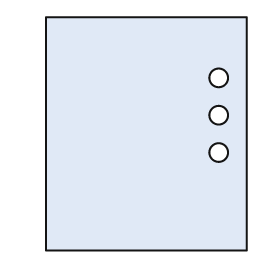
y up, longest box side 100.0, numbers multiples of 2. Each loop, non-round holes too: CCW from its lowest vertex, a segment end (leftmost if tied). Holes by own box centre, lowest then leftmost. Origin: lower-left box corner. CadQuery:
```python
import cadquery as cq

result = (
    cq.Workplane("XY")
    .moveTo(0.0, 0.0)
    .lineTo(86.0, 0.0)
    .lineTo(86.0, 100.0)
    .lineTo(0.0, 100.0)
    .close()
    .moveTo(74.0, 42.0)
    .circle(4.0)
    .moveTo(74.0, 58.0)
    .circle(4.0)
    .moveTo(74.0, 74.0)
    .circle(4.0)
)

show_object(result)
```